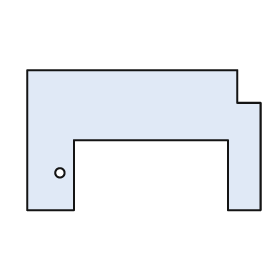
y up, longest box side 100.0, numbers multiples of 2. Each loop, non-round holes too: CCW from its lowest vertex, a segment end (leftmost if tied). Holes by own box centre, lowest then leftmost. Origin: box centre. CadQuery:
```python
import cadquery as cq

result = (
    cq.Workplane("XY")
    .moveTo(-50.0, -30.0)
    .lineTo(-30.0, -30.0)
    .lineTo(-30.0, 0.0)
    .lineTo(36.0, 0.0)
    .lineTo(36.0, -30.0)
    .lineTo(50.0, -30.0)
    .lineTo(50.0, 16.0)
    .lineTo(40.0, 16.0)
    .lineTo(40.0, 30.0)
    .lineTo(-50.0, 30.0)
    .close()
    .moveTo(-36.0, -14.0)
    .circle(2.0)
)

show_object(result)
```